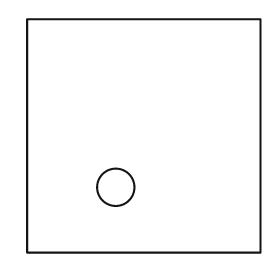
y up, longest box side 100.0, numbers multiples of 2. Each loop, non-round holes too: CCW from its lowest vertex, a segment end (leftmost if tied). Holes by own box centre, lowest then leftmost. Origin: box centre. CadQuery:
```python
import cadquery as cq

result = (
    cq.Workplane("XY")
    .moveTo(-50.0, -50.0)
    .lineTo(50.0, -50.0)
    .lineTo(50.0, 50.0)
    .lineTo(-50.0, 50.0)
    .close()
    .moveTo(-12.0, -22.0)
    .circle(8.0)
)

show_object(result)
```